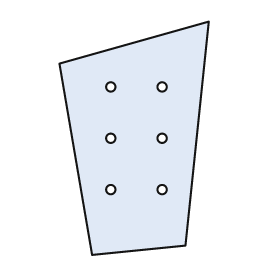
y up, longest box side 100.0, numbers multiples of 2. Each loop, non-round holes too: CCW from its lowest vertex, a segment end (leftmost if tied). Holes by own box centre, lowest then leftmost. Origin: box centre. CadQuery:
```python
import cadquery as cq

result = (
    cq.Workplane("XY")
    .moveTo(-18.0, -50.0)
    .lineTo(22.0, -46.0)
    .lineTo(32.0, 50.0)
    .lineTo(-32.0, 32.0)
    .close()
    .moveTo(-10.0, -22.0)
    .circle(2.0)
    .moveTo(12.0, -22.0)
    .circle(2.0)
    .moveTo(-10.0, 0.0)
    .circle(2.0)
    .moveTo(12.0, 0.0)
    .circle(2.0)
    .moveTo(-10.0, 22.0)
    .circle(2.0)
    .moveTo(12.0, 22.0)
    .circle(2.0)
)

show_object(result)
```